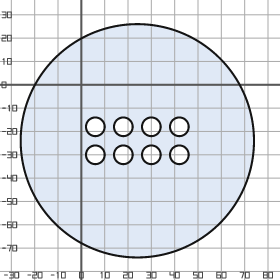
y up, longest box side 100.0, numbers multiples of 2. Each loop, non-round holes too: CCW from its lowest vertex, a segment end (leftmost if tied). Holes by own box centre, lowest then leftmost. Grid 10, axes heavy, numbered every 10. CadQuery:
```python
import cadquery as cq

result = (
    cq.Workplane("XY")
    .moveTo(24.0, -24.0)
    .circle(50.0)
    .moveTo(6.0, -30.0)
    .circle(4.0)
    .moveTo(18.0, -30.0)
    .circle(4.0)
    .moveTo(30.0, -30.0)
    .circle(4.0)
    .moveTo(42.0, -30.0)
    .circle(4.0)
    .moveTo(6.0, -18.0)
    .circle(4.0)
    .moveTo(18.0, -18.0)
    .circle(4.0)
    .moveTo(30.0, -18.0)
    .circle(4.0)
    .moveTo(42.0, -18.0)
    .circle(4.0)
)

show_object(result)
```